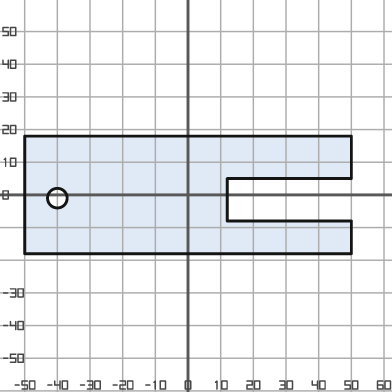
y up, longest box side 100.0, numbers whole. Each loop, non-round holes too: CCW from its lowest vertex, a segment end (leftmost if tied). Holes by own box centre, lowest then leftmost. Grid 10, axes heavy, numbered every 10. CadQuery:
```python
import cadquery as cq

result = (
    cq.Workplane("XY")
    .moveTo(-50.0, -18.0)
    .lineTo(50.0, -18.0)
    .lineTo(50.0, -8.0)
    .lineTo(12.0, -8.0)
    .lineTo(12.0, 5.0)
    .lineTo(50.0, 5.0)
    .lineTo(50.0, 18.0)
    .lineTo(-50.0, 18.0)
    .close()
    .moveTo(-40.0, -1.0)
    .circle(3.0)
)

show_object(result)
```